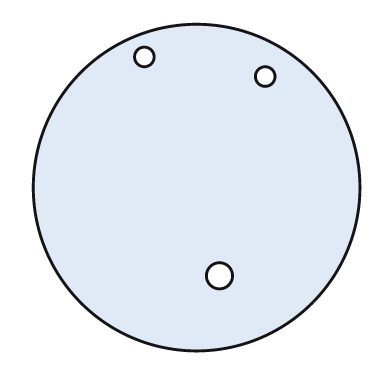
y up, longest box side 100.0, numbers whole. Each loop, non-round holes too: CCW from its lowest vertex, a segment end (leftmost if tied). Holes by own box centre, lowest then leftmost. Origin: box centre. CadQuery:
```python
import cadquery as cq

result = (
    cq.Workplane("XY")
    .moveTo(0.0, 0.0)
    .circle(50.0)
    .moveTo(7.0, -27.0)
    .circle(4.0)
    .moveTo(21.0, 34.0)
    .circle(3.0)
    .moveTo(-16.0, 40.0)
    .circle(3.0)
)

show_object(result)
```